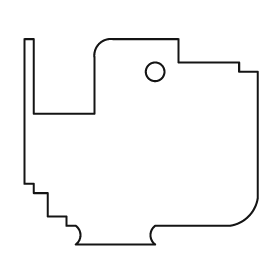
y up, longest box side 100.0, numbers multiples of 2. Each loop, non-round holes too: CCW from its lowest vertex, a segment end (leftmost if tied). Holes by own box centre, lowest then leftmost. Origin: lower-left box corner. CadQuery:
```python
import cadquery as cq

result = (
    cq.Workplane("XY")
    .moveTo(22.0, 0.0)
    .lineTo(56.0, 0.0)
    .threePointArc((54.0, 4.0), (56.0, 8.0))
    .lineTo(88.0, 8.0)
    .threePointArc((96.0, 12.0), (100.0, 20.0))
    .lineTo(100.0, 74.0)
    .lineTo(92.0, 74.0)
    .lineTo(92.0, 78.0)
    .lineTo(66.0, 78.0)
    .lineTo(66.0, 88.0)
    .lineTo(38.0, 88.0)
    .threePointArc((32.0, 86.0), (30.0, 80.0))
    .lineTo(30.0, 56.0)
    .lineTo(4.0, 56.0)
    .lineTo(4.0, 88.0)
    .lineTo(0.0, 88.0)
    .lineTo(0.0, 26.0)
    .lineTo(4.0, 26.0)
    .lineTo(4.0, 22.0)
    .lineTo(10.0, 22.0)
    .lineTo(10.0, 12.0)
    .lineTo(18.0, 12.0)
    .lineTo(18.0, 8.0)
    .lineTo(22.0, 8.0)
    .threePointArc((24.0, 4.0), (22.0, 0.0))
    .close()
    .moveTo(56.0, 74.0)
    .circle(4.0)
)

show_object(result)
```